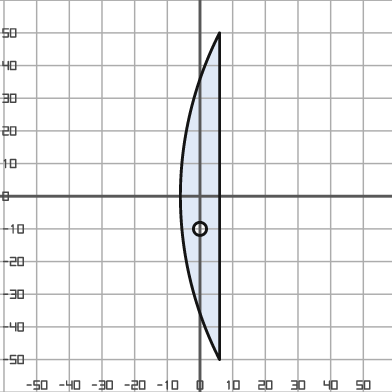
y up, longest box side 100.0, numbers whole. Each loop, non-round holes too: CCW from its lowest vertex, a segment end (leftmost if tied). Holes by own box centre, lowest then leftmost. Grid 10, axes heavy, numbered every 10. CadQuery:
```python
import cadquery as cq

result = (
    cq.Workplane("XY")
    .moveTo(6.0, -50.0)
    .lineTo(6.0, 50.0)
    .threePointArc((-6.0, 0.0), (6.0, -50.0))
    .close()
    .moveTo(0.0, -10.0)
    .circle(2.0)
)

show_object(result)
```